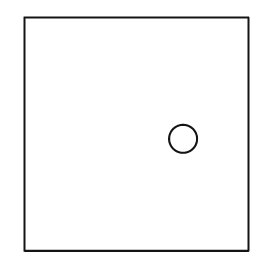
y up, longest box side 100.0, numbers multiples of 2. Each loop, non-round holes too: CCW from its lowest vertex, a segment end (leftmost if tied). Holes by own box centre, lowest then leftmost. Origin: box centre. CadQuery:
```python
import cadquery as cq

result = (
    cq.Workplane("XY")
    .moveTo(-48.0, -50.0)
    .lineTo(48.0, -50.0)
    .lineTo(48.0, 50.0)
    .lineTo(-48.0, 50.0)
    .close()
    .moveTo(20.0, -2.0)
    .circle(6.0)
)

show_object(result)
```